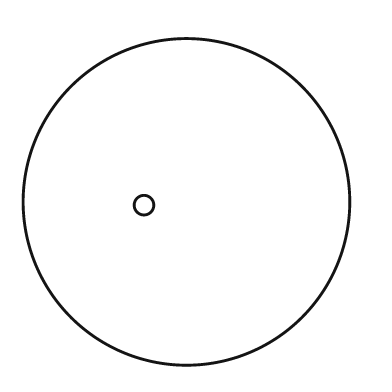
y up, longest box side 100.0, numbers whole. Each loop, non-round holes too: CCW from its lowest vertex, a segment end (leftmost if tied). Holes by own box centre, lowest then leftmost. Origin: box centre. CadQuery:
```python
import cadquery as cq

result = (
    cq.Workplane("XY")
    .moveTo(0.0, 0.0)
    .circle(50.0)
    .moveTo(-13.0, -1.0)
    .circle(3.0)
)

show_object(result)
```